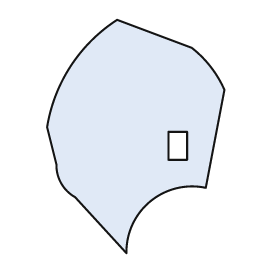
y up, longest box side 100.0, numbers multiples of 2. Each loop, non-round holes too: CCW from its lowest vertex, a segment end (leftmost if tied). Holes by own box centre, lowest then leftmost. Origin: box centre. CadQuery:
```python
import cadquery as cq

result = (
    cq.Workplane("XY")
    .moveTo(-4.0, -50.0)
    .threePointArc((6.0, -28.0), (30.0, -22.0))
    .lineTo(38.0, 20.0)
    .threePointArc((32.0, 30.0), (24.0, 38.0))
    .lineTo(-8.0, 50.0)
    .threePointArc((-28.0, 30.0), (-38.0, 4.0))
    .lineTo(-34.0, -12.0)
    .threePointArc((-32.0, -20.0), (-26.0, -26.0))
    .close()
    .moveTo(14.0, -10.0)
    .lineTo(22.0, -10.0)
    .lineTo(22.0, 2.0)
    .lineTo(14.0, 2.0)
    .close()
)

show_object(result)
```